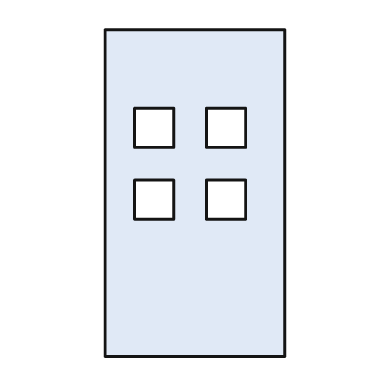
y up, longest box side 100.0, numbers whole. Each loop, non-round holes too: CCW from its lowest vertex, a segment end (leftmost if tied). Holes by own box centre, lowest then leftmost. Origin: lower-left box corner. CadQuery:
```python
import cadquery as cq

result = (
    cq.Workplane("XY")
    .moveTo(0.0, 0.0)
    .lineTo(55.0, 0.0)
    .lineTo(55.0, 100.0)
    .lineTo(0.0, 100.0)
    .close()
    .moveTo(9.0, 42.0)
    .lineTo(21.0, 42.0)
    .lineTo(21.0, 54.0)
    .lineTo(9.0, 54.0)
    .close()
    .moveTo(31.0, 42.0)
    .lineTo(43.0, 42.0)
    .lineTo(43.0, 54.0)
    .lineTo(31.0, 54.0)
    .close()
    .moveTo(9.0, 64.0)
    .lineTo(21.0, 64.0)
    .lineTo(21.0, 76.0)
    .lineTo(9.0, 76.0)
    .close()
    .moveTo(31.0, 64.0)
    .lineTo(43.0, 64.0)
    .lineTo(43.0, 76.0)
    .lineTo(31.0, 76.0)
    .close()
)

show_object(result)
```